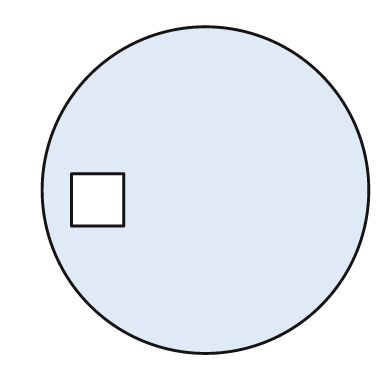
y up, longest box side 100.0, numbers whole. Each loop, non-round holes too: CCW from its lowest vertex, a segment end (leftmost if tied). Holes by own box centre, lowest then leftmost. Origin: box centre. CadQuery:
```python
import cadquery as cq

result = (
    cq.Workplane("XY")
    .moveTo(0.0, 0.0)
    .circle(50.0)
    .moveTo(-41.0, -11.0)
    .lineTo(-25.0, -11.0)
    .lineTo(-25.0, 5.0)
    .lineTo(-41.0, 5.0)
    .close()
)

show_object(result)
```